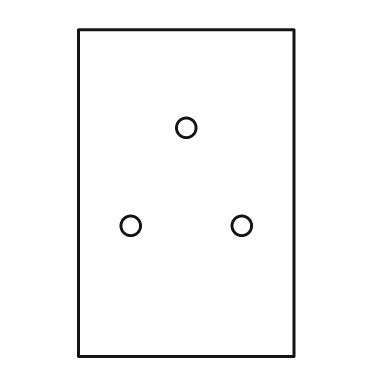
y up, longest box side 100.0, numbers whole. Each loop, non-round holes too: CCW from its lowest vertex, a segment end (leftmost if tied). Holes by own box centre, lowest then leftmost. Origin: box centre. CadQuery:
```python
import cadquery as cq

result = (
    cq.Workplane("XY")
    .moveTo(-33.0, -50.0)
    .lineTo(33.0, -50.0)
    .lineTo(33.0, 50.0)
    .lineTo(-33.0, 50.0)
    .close()
    .moveTo(-17.0, -10.0)
    .circle(3.0)
    .moveTo(17.0, -10.0)
    .circle(3.0)
    .moveTo(0.0, 20.0)
    .circle(3.0)
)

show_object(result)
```